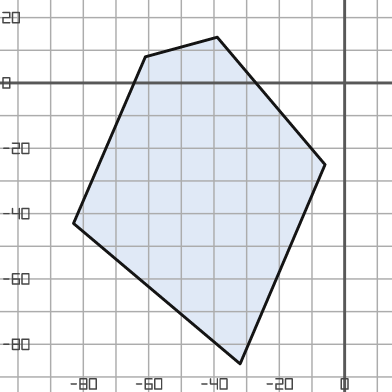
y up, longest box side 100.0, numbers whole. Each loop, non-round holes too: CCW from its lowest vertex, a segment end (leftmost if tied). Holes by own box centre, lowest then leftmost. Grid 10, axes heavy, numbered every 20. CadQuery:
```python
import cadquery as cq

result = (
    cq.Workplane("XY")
    .moveTo(-32.0, -86.0)
    .lineTo(-6.0, -25.0)
    .lineTo(-39.0, 14.0)
    .lineTo(-61.0, 8.0)
    .lineTo(-83.0, -43.0)
    .close()
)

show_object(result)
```